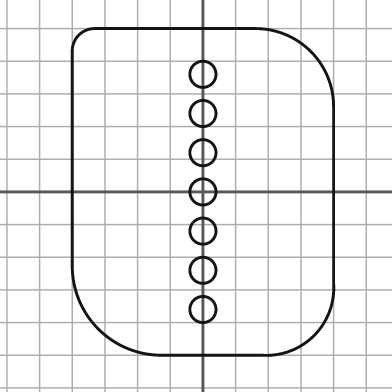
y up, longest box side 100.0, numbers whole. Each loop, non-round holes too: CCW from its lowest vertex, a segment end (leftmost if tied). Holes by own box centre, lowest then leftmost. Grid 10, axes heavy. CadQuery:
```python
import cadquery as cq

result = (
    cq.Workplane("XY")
    .moveTo(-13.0, -50.0)
    .lineTo(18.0, -50.0)
    .threePointArc((34.0, -44.0), (40.0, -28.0))
    .lineTo(40.0, 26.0)
    .threePointArc((33.0, 43.0), (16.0, 50.0))
    .lineTo(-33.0, 50.0)
    .threePointArc((-38.0, 48.0), (-40.0, 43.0))
    .lineTo(-40.0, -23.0)
    .threePointArc((-32.0, -42.0), (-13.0, -50.0))
    .close()
    .moveTo(0.0, -36.0)
    .circle(4.0)
    .moveTo(0.0, -24.0)
    .circle(4.0)
    .moveTo(0.0, -12.0)
    .circle(4.0)
    .moveTo(0.0, 0.0)
    .circle(4.0)
    .moveTo(0.0, 12.0)
    .circle(4.0)
    .moveTo(0.0, 24.0)
    .circle(4.0)
    .moveTo(0.0, 36.0)
    .circle(4.0)
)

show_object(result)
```